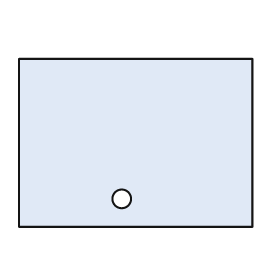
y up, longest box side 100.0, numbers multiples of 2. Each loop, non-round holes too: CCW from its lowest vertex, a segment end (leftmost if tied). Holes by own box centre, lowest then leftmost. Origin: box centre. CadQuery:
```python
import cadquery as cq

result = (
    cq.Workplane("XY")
    .moveTo(-50.0, -36.0)
    .lineTo(50.0, -36.0)
    .lineTo(50.0, 36.0)
    .lineTo(-50.0, 36.0)
    .close()
    .moveTo(-6.0, -24.0)
    .circle(4.0)
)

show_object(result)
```